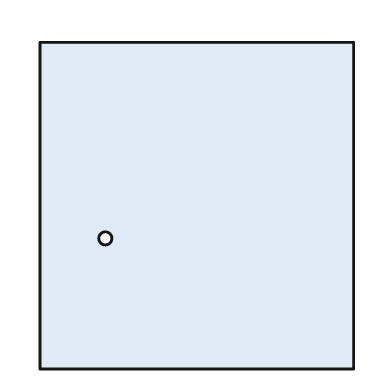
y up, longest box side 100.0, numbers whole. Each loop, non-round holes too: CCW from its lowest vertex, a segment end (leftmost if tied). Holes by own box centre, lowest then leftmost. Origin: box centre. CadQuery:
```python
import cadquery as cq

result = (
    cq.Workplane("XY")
    .moveTo(-48.0, -50.0)
    .lineTo(48.0, -50.0)
    .lineTo(48.0, 50.0)
    .lineTo(-48.0, 50.0)
    .close()
    .moveTo(-28.0, -10.0)
    .circle(2.0)
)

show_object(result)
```